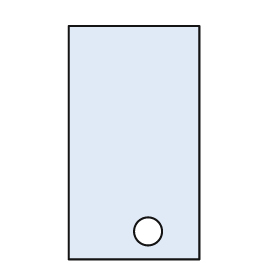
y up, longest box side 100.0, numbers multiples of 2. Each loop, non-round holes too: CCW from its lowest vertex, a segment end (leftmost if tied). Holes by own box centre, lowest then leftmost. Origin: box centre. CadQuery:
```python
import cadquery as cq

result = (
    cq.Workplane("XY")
    .moveTo(-28.0, -50.0)
    .lineTo(28.0, -50.0)
    .lineTo(28.0, 50.0)
    .lineTo(-28.0, 50.0)
    .close()
    .moveTo(6.0, -38.0)
    .circle(6.0)
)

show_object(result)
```